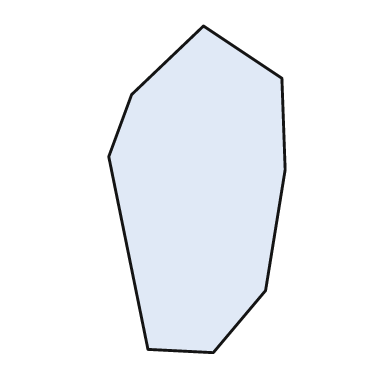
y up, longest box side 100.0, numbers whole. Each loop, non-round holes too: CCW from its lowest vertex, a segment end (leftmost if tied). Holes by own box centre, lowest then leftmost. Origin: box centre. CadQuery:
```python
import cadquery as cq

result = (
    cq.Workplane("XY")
    .moveTo(5.0, -50.0)
    .lineTo(21.0, -31.0)
    .lineTo(27.0, 6.0)
    .lineTo(26.0, 34.0)
    .lineTo(2.0, 50.0)
    .lineTo(-20.0, 29.0)
    .lineTo(-27.0, 10.0)
    .lineTo(-15.0, -49.0)
    .close()
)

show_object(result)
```